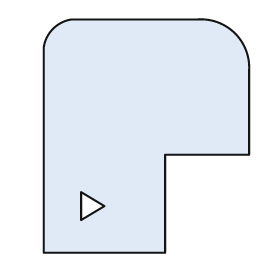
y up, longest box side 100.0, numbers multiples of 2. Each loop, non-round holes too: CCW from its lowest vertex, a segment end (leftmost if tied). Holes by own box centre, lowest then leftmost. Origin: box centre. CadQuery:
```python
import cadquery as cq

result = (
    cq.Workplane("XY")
    .moveTo(-44.0, -50.0)
    .lineTo(8.0, -50.0)
    .lineTo(8.0, -8.0)
    .lineTo(44.0, -8.0)
    .lineTo(44.0, 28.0)
    .threePointArc((38.0, 44.0), (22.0, 50.0))
    .lineTo(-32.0, 50.0)
    .threePointArc((-40.0, 46.0), (-44.0, 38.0))
    .close()
    .moveTo(-28.0, -36.0)
    .lineTo(-18.0, -30.0)
    .lineTo(-28.0, -24.0)
    .close()
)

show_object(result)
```